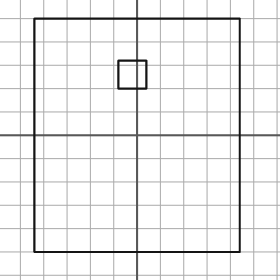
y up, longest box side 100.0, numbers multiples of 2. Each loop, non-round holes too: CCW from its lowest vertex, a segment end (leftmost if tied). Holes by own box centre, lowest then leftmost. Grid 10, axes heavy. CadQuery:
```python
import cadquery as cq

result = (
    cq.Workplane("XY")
    .moveTo(-44.0, -50.0)
    .lineTo(44.0, -50.0)
    .lineTo(44.0, 50.0)
    .lineTo(-44.0, 50.0)
    .close()
    .moveTo(-8.0, 20.0)
    .lineTo(4.0, 20.0)
    .lineTo(4.0, 32.0)
    .lineTo(-8.0, 32.0)
    .close()
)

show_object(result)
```